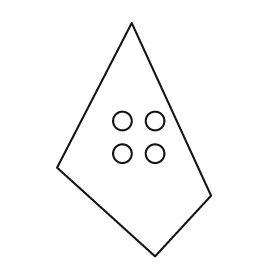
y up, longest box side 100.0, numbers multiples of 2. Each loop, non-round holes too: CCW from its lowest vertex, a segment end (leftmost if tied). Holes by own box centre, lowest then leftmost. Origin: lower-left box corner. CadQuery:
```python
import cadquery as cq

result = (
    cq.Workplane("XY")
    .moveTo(42.0, 0.0)
    .lineTo(66.0, 26.0)
    .lineTo(32.0, 100.0)
    .lineTo(0.0, 38.0)
    .close()
    .moveTo(28.0, 44.0)
    .circle(4.0)
    .moveTo(42.0, 44.0)
    .circle(4.0)
    .moveTo(28.0, 58.0)
    .circle(4.0)
    .moveTo(42.0, 58.0)
    .circle(4.0)
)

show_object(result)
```